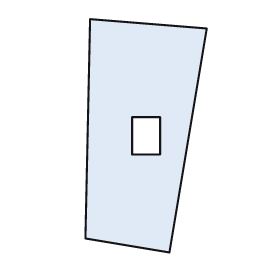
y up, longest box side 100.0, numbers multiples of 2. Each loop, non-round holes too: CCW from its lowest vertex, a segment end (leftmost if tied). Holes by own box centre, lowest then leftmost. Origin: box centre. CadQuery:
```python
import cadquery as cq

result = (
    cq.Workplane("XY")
    .moveTo(10.0, -50.0)
    .lineTo(26.0, 46.0)
    .lineTo(-24.0, 50.0)
    .lineTo(-26.0, -44.0)
    .close()
    .moveTo(-6.0, -8.0)
    .lineTo(6.0, -8.0)
    .lineTo(6.0, 8.0)
    .lineTo(-6.0, 8.0)
    .close()
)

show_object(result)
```